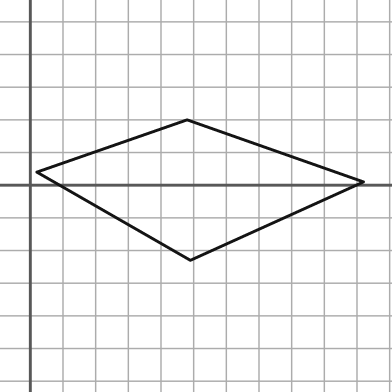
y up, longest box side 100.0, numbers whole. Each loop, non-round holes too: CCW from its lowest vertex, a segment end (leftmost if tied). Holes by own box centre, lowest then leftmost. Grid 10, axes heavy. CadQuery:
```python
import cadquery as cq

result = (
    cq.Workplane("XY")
    .moveTo(49.0, -23.0)
    .lineTo(102.0, 1.0)
    .lineTo(48.0, 20.0)
    .lineTo(2.0, 4.0)
    .close()
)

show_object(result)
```